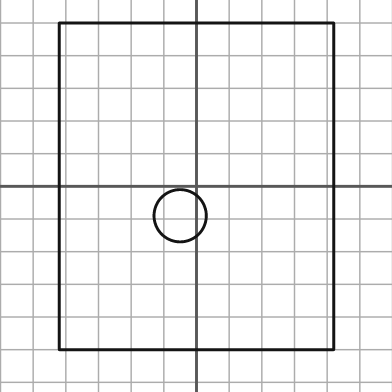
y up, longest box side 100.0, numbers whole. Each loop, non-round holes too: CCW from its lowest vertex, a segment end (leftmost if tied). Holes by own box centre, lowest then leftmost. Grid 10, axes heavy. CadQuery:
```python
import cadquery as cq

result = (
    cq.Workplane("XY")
    .moveTo(-42.0, -50.0)
    .lineTo(42.0, -50.0)
    .lineTo(42.0, 50.0)
    .lineTo(-42.0, 50.0)
    .close()
    .moveTo(-5.0, -9.0)
    .circle(8.0)
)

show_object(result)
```